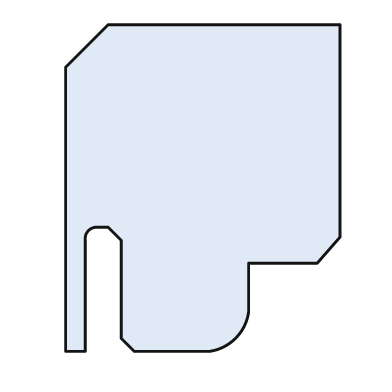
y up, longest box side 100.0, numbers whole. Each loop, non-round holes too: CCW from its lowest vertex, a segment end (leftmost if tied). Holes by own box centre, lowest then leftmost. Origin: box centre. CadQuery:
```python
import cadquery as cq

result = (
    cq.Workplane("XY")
    .moveTo(-42.0, -50.0)
    .lineTo(-36.0, -50.0)
    .lineTo(-36.0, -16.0)
    .threePointArc((-35.0, -13.0), (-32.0, -12.0))
    .lineTo(-29.0, -12.0)
    .lineTo(-25.0, -16.0)
    .lineTo(-25.0, -46.0)
    .lineTo(-21.0, -50.0)
    .lineTo(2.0, -50.0)
    .threePointArc((10.0, -46.0), (14.0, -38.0))
    .lineTo(14.0, -23.0)
    .lineTo(35.0, -23.0)
    .lineTo(42.0, -15.0)
    .lineTo(42.0, 50.0)
    .lineTo(-29.0, 50.0)
    .lineTo(-42.0, 37.0)
    .close()
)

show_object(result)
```